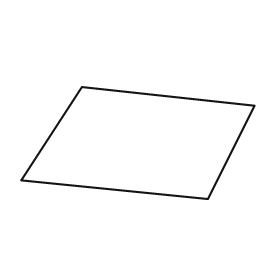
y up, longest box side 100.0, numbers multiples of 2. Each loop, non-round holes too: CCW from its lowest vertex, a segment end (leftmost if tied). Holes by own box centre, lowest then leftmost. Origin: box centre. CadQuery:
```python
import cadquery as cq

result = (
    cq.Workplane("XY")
    .moveTo(30.0, -24.0)
    .lineTo(50.0, 16.0)
    .lineTo(-24.0, 24.0)
    .lineTo(-50.0, -16.0)
    .close()
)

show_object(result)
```